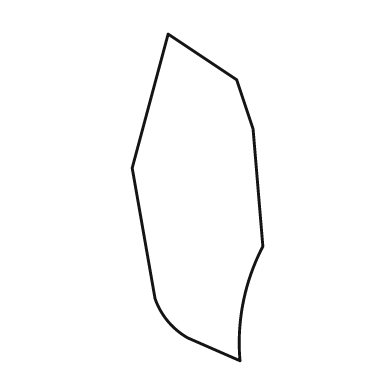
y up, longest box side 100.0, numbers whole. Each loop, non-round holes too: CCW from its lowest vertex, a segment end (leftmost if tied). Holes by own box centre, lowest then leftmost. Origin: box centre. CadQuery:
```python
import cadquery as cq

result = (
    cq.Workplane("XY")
    .moveTo(13.0, -50.0)
    .threePointArc((14.0, -32.0), (20.0, -15.0))
    .lineTo(17.0, 21.0)
    .lineTo(12.0, 36.0)
    .lineTo(-9.0, 50.0)
    .lineTo(-20.0, 9.0)
    .lineTo(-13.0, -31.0)
    .threePointArc((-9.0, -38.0), (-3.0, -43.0))
    .close()
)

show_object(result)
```